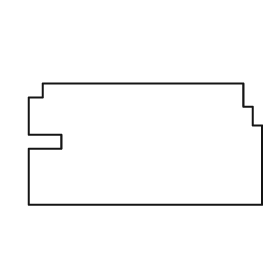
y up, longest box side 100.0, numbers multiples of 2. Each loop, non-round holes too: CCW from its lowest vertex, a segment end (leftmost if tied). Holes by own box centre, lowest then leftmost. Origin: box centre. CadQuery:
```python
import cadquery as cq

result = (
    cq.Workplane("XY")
    .moveTo(-50.0, -26.0)
    .lineTo(50.0, -26.0)
    .lineTo(50.0, 8.0)
    .lineTo(46.0, 8.0)
    .lineTo(46.0, 16.0)
    .lineTo(42.0, 16.0)
    .lineTo(42.0, 26.0)
    .lineTo(-44.0, 26.0)
    .lineTo(-44.0, 20.0)
    .lineTo(-50.0, 20.0)
    .lineTo(-50.0, 4.0)
    .lineTo(-36.0, 4.0)
    .lineTo(-36.0, -2.0)
    .lineTo(-50.0, -2.0)
    .close()
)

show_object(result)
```